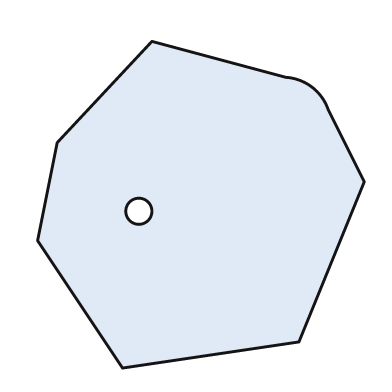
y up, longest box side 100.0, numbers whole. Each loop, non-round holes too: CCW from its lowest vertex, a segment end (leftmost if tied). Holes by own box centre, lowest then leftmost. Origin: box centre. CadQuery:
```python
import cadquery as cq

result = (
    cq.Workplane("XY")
    .moveTo(-24.0, -50.0)
    .lineTo(30.0, -42.0)
    .lineTo(50.0, 7.0)
    .lineTo(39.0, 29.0)
    .threePointArc((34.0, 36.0), (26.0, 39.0))
    .lineTo(-15.0, 50.0)
    .lineTo(-44.0, 19.0)
    .lineTo(-50.0, -11.0)
    .close()
    .moveTo(-19.0, -2.0)
    .circle(4.0)
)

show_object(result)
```